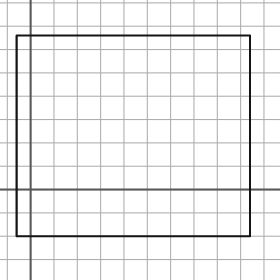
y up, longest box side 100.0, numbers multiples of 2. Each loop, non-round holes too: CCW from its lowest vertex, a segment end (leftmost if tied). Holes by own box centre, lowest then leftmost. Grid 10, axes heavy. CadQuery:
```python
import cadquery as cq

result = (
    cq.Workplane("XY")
    .moveTo(-6.0, -20.0)
    .lineTo(94.0, -20.0)
    .lineTo(94.0, 66.0)
    .lineTo(-6.0, 66.0)
    .close()
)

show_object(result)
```